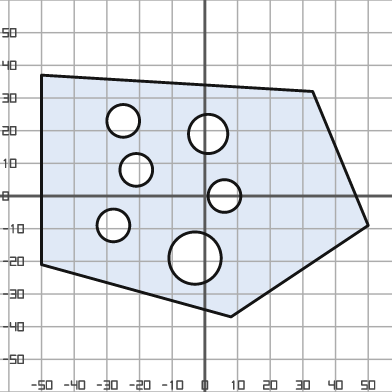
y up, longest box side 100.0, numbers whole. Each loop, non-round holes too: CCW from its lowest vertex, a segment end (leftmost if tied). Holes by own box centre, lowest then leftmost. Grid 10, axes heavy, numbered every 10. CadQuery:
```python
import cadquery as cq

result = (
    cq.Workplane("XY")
    .moveTo(8.0, -37.0)
    .lineTo(50.0, -9.0)
    .lineTo(33.0, 32.0)
    .lineTo(-50.0, 37.0)
    .lineTo(-50.0, -21.0)
    .close()
    .moveTo(-3.0, -19.0)
    .circle(8.0)
    .moveTo(-28.0, -9.0)
    .circle(5.0)
    .moveTo(6.0, 0.0)
    .circle(5.0)
    .moveTo(-21.0, 8.0)
    .circle(5.0)
    .moveTo(1.0, 19.0)
    .circle(6.0)
    .moveTo(-25.0, 23.0)
    .circle(5.0)
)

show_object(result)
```